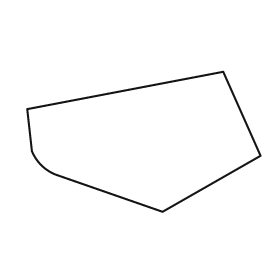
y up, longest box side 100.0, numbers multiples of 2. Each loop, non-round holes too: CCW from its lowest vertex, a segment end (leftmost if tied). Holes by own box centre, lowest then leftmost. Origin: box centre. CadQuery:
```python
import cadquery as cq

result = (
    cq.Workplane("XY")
    .moveTo(8.0, -30.0)
    .lineTo(50.0, -6.0)
    .lineTo(34.0, 30.0)
    .lineTo(-50.0, 14.0)
    .lineTo(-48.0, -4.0)
    .threePointArc((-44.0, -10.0), (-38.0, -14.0))
    .close()
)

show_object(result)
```